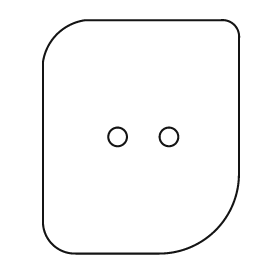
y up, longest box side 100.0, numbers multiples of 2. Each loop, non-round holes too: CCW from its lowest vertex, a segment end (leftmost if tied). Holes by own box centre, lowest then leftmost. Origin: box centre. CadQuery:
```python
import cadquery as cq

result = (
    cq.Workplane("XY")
    .moveTo(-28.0, -50.0)
    .lineTo(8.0, -50.0)
    .threePointArc((32.0, -40.0), (42.0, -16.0))
    .lineTo(42.0, 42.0)
    .threePointArc((40.0, 48.0), (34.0, 50.0))
    .lineTo(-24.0, 50.0)
    .threePointArc((-36.0, 44.0), (-42.0, 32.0))
    .lineTo(-42.0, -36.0)
    .threePointArc((-38.0, -46.0), (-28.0, -50.0))
    .close()
    .moveTo(-10.0, 0.0)
    .circle(4.0)
    .moveTo(12.0, 0.0)
    .circle(4.0)
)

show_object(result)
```